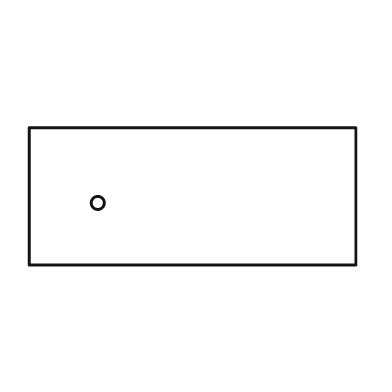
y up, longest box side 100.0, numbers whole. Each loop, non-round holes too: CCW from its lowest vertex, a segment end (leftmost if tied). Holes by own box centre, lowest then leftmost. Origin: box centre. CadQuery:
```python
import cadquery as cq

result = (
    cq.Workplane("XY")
    .moveTo(-50.0, -21.0)
    .lineTo(50.0, -21.0)
    .lineTo(50.0, 21.0)
    .lineTo(-50.0, 21.0)
    .close()
    .moveTo(-29.0, -2.0)
    .circle(2.0)
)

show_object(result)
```